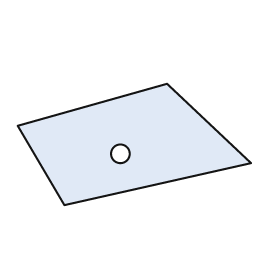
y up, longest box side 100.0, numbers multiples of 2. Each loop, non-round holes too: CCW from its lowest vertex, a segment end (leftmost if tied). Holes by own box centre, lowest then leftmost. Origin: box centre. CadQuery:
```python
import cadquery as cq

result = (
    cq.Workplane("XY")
    .moveTo(-30.0, -26.0)
    .lineTo(50.0, -8.0)
    .lineTo(14.0, 26.0)
    .lineTo(-50.0, 8.0)
    .close()
    .moveTo(-6.0, -4.0)
    .circle(4.0)
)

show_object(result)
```